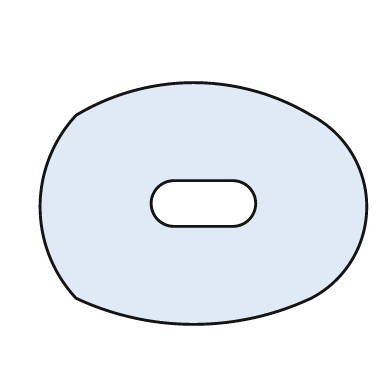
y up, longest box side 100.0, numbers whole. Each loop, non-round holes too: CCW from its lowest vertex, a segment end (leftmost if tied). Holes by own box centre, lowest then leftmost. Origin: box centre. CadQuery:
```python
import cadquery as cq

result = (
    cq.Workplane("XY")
    .moveTo(-39.0, -29.0)
    .threePointArc((-3.0, -37.0), (33.0, -29.0))
    .threePointArc((50.0, -1.0), (33.0, 27.0))
    .threePointArc((-3.0, 37.0), (-39.0, 27.0))
    .threePointArc((-50.0, -1.0), (-39.0, -29.0))
    .close()
    .moveTo(-9.0, -7.0)
    .lineTo(9.0, -7.0)
    .threePointArc((16.0, 0.0), (9.0, 7.0))
    .lineTo(-9.0, 7.0)
    .threePointArc((-16.0, 0.0), (-9.0, -7.0))
    .close()
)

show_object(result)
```